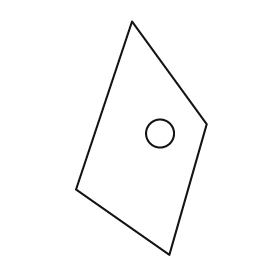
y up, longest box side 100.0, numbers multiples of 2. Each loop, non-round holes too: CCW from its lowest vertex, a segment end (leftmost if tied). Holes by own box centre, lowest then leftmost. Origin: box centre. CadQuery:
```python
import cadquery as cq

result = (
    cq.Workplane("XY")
    .moveTo(12.0, -50.0)
    .lineTo(28.0, 6.0)
    .lineTo(-4.0, 50.0)
    .lineTo(-28.0, -22.0)
    .close()
    .moveTo(8.0, 2.0)
    .circle(6.0)
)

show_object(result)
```